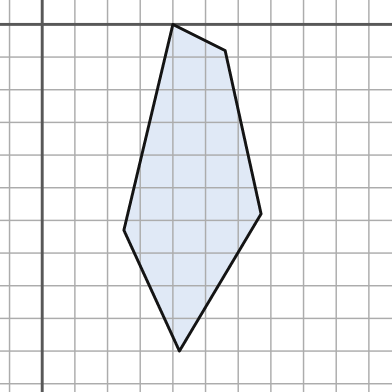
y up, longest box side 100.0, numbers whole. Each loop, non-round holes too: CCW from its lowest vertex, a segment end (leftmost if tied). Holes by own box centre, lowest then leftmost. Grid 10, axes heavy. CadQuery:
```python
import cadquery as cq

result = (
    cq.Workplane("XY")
    .moveTo(42.0, -100.0)
    .lineTo(67.0, -58.0)
    .lineTo(56.0, -8.0)
    .lineTo(40.0, 0.0)
    .lineTo(25.0, -63.0)
    .close()
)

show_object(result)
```